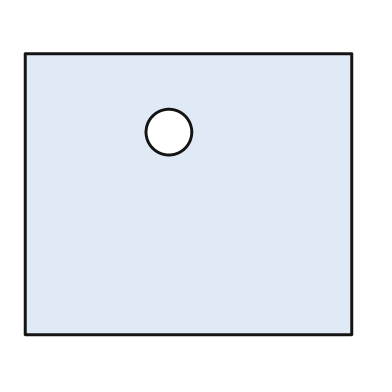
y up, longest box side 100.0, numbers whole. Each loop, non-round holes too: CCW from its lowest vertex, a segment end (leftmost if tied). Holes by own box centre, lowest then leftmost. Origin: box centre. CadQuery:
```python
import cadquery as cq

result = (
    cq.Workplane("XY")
    .moveTo(-50.0, -43.0)
    .lineTo(50.0, -43.0)
    .lineTo(50.0, 43.0)
    .lineTo(-50.0, 43.0)
    .close()
    .moveTo(-6.0, 19.0)
    .circle(7.0)
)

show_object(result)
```